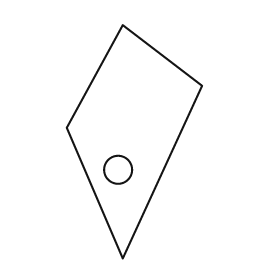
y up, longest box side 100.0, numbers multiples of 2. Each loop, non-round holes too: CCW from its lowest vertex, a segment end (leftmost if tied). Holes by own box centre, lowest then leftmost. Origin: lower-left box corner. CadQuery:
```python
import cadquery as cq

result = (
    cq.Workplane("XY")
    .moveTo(24.0, 0.0)
    .lineTo(58.0, 74.0)
    .lineTo(24.0, 100.0)
    .lineTo(0.0, 56.0)
    .close()
    .moveTo(22.0, 38.0)
    .circle(6.0)
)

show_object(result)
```